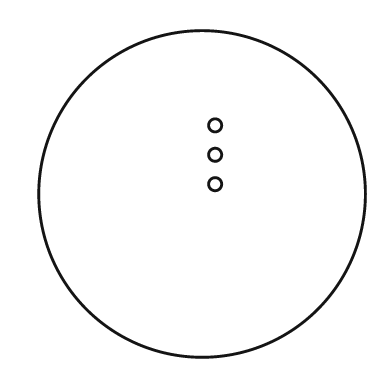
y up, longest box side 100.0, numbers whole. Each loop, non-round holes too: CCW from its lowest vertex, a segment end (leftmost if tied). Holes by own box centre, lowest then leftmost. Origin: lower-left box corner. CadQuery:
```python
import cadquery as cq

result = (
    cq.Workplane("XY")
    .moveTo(50.0, 50.0)
    .circle(50.0)
    .moveTo(54.0, 53.0)
    .circle(2.0)
    .moveTo(54.0, 62.0)
    .circle(2.0)
    .moveTo(54.0, 71.0)
    .circle(2.0)
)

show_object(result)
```